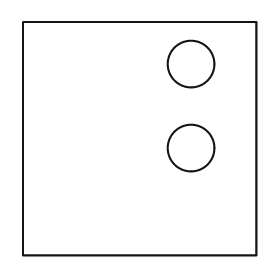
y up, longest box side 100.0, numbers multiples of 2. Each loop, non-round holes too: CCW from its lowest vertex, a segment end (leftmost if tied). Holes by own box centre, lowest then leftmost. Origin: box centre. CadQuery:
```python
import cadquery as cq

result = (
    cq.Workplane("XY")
    .moveTo(-50.0, -50.0)
    .lineTo(50.0, -50.0)
    .lineTo(50.0, 50.0)
    .lineTo(-50.0, 50.0)
    .close()
    .moveTo(22.0, -4.0)
    .circle(10.0)
    .moveTo(22.0, 32.0)
    .circle(10.0)
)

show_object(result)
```